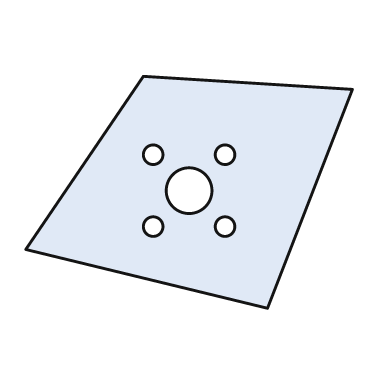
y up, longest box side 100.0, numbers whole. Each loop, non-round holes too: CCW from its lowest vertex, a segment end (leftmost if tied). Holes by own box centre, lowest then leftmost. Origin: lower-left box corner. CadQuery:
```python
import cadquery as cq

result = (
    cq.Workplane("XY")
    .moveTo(74.0, 0.0)
    .lineTo(100.0, 67.0)
    .lineTo(36.0, 71.0)
    .lineTo(0.0, 18.0)
    .close()
    .moveTo(39.0, 25.0)
    .circle(3.0)
    .moveTo(61.0, 25.0)
    .circle(3.0)
    .moveTo(50.0, 36.0)
    .circle(7.0)
    .moveTo(39.0, 47.0)
    .circle(3.0)
    .moveTo(61.0, 47.0)
    .circle(3.0)
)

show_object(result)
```